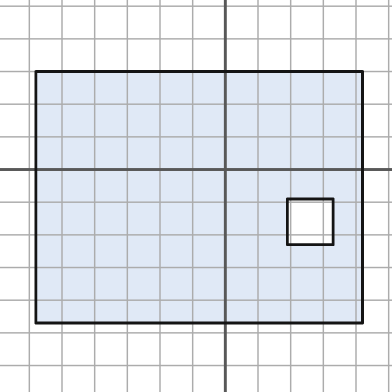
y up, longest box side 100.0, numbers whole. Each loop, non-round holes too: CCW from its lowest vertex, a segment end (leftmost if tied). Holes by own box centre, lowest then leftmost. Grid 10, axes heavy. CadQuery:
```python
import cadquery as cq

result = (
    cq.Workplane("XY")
    .moveTo(-58.0, -47.0)
    .lineTo(42.0, -47.0)
    .lineTo(42.0, 30.0)
    .lineTo(-58.0, 30.0)
    .close()
    .moveTo(19.0, -23.0)
    .lineTo(33.0, -23.0)
    .lineTo(33.0, -9.0)
    .lineTo(19.0, -9.0)
    .close()
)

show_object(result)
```